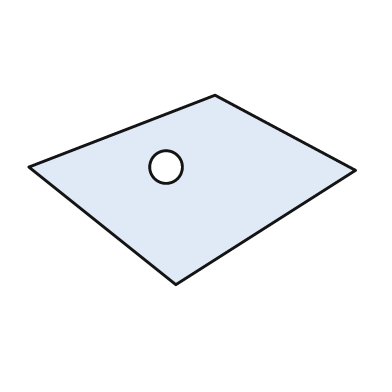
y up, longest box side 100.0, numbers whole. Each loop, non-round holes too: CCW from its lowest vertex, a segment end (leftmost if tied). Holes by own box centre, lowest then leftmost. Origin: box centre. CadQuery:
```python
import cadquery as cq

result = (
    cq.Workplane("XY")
    .moveTo(-5.0, -29.0)
    .lineTo(50.0, 6.0)
    .lineTo(7.0, 29.0)
    .lineTo(-50.0, 7.0)
    .close()
    .moveTo(-8.0, 7.0)
    .circle(5.0)
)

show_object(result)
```